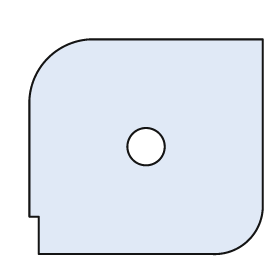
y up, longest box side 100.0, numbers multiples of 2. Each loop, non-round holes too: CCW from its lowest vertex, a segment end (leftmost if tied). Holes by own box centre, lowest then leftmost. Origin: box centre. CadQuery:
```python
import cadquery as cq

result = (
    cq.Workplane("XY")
    .moveTo(-46.0, -46.0)
    .lineTo(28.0, -46.0)
    .threePointArc((44.0, -40.0), (50.0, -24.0))
    .lineTo(50.0, 46.0)
    .lineTo(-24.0, 46.0)
    .threePointArc((-42.0, 38.0), (-50.0, 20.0))
    .lineTo(-50.0, -30.0)
    .lineTo(-46.0, -30.0)
    .close()
    .moveTo(0.0, 0.0)
    .circle(8.0)
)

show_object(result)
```